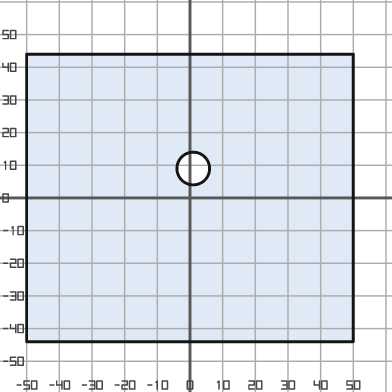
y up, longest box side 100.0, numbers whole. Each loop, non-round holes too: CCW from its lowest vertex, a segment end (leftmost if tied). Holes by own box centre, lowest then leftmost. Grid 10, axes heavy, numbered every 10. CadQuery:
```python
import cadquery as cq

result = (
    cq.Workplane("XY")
    .moveTo(-50.0, -44.0)
    .lineTo(50.0, -44.0)
    .lineTo(50.0, 44.0)
    .lineTo(-50.0, 44.0)
    .close()
    .moveTo(1.0, 9.0)
    .circle(5.0)
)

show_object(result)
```